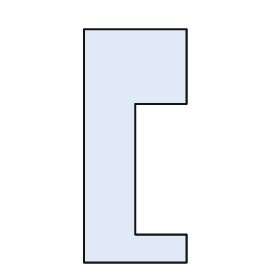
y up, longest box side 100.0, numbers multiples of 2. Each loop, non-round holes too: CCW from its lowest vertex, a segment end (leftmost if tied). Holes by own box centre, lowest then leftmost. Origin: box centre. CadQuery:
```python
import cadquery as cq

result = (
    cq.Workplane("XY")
    .moveTo(-22.0, -50.0)
    .lineTo(22.0, -50.0)
    .lineTo(22.0, -38.0)
    .lineTo(0.0, -38.0)
    .lineTo(0.0, 18.0)
    .lineTo(22.0, 18.0)
    .lineTo(22.0, 50.0)
    .lineTo(-22.0, 50.0)
    .close()
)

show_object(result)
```